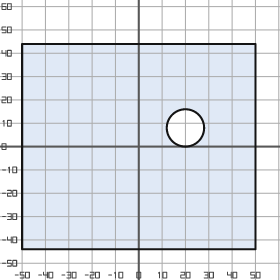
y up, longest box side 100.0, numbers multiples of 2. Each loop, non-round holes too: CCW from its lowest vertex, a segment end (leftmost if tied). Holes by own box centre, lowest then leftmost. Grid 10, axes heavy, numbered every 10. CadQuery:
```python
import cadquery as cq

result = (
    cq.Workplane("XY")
    .moveTo(-50.0, -44.0)
    .lineTo(50.0, -44.0)
    .lineTo(50.0, 44.0)
    .lineTo(-50.0, 44.0)
    .close()
    .moveTo(20.0, 8.0)
    .circle(8.0)
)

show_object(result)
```